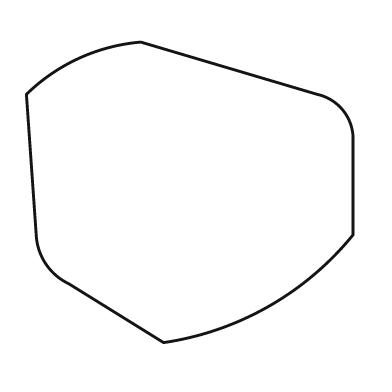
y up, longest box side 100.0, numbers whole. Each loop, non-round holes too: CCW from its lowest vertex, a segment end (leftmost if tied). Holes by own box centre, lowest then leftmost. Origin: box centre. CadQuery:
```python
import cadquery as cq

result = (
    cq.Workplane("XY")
    .moveTo(-8.0, -46.0)
    .threePointArc((24.0, -35.0), (50.0, -13.0))
    .lineTo(50.0, 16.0)
    .threePointArc((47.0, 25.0), (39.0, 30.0))
    .lineTo(-15.0, 46.0)
    .threePointArc((-34.0, 41.0), (-50.0, 30.0))
    .lineTo(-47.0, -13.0)
    .threePointArc((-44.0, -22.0), (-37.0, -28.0))
    .close()
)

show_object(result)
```